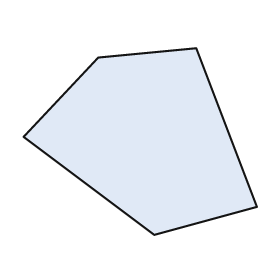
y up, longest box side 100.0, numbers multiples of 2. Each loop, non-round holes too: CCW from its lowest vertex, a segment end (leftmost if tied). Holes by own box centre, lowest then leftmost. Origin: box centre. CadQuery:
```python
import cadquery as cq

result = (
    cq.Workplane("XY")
    .moveTo(6.0, -40.0)
    .lineTo(50.0, -28.0)
    .lineTo(24.0, 40.0)
    .lineTo(-18.0, 36.0)
    .lineTo(-50.0, 2.0)
    .close()
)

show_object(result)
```